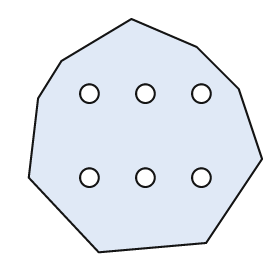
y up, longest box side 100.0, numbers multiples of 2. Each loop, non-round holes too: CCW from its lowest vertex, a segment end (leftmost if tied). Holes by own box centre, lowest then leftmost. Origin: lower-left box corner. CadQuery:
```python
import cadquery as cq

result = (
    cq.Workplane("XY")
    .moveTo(30.0, 0.0)
    .lineTo(76.0, 4.0)
    .lineTo(100.0, 40.0)
    .lineTo(90.0, 70.0)
    .lineTo(72.0, 88.0)
    .lineTo(44.0, 100.0)
    .lineTo(14.0, 82.0)
    .lineTo(4.0, 66.0)
    .lineTo(0.0, 32.0)
    .close()
    .moveTo(26.0, 32.0)
    .circle(4.0)
    .moveTo(50.0, 32.0)
    .circle(4.0)
    .moveTo(74.0, 32.0)
    .circle(4.0)
    .moveTo(26.0, 68.0)
    .circle(4.0)
    .moveTo(50.0, 68.0)
    .circle(4.0)
    .moveTo(74.0, 68.0)
    .circle(4.0)
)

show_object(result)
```